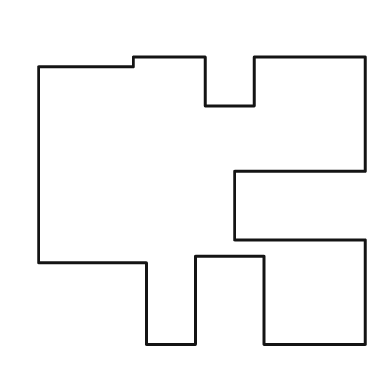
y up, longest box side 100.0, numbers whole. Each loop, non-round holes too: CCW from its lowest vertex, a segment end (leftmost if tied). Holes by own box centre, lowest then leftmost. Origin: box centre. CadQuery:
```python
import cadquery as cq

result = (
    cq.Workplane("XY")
    .moveTo(-17.0, -44.0)
    .lineTo(-2.0, -44.0)
    .lineTo(-2.0, -17.0)
    .lineTo(19.0, -17.0)
    .lineTo(19.0, -44.0)
    .lineTo(50.0, -44.0)
    .lineTo(50.0, -12.0)
    .lineTo(10.0, -12.0)
    .lineTo(10.0, 9.0)
    .lineTo(50.0, 9.0)
    .lineTo(50.0, 44.0)
    .lineTo(16.0, 44.0)
    .lineTo(16.0, 29.0)
    .lineTo(1.0, 29.0)
    .lineTo(1.0, 44.0)
    .lineTo(-21.0, 44.0)
    .lineTo(-21.0, 41.0)
    .lineTo(-50.0, 41.0)
    .lineTo(-50.0, -19.0)
    .lineTo(-17.0, -19.0)
    .close()
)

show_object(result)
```